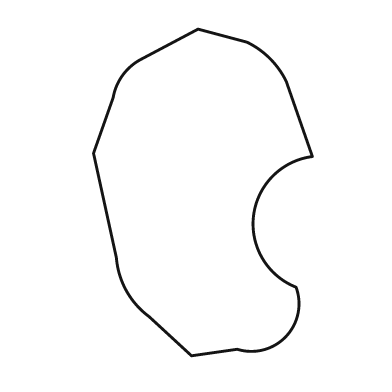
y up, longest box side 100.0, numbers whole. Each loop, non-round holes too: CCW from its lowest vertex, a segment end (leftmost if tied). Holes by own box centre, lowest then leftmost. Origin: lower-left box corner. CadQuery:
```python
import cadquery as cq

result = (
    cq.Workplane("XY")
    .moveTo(30.0, 0.0)
    .lineTo(44.0, 2.0)
    .threePointArc((59.0, 6.0), (62.0, 21.0))
    .threePointArc((49.0, 43.0), (67.0, 61.0))
    .lineTo(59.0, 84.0)
    .threePointArc((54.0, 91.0), (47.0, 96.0))
    .lineTo(32.0, 100.0)
    .lineTo(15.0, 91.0)
    .threePointArc((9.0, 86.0), (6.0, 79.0))
    .lineTo(0.0, 62.0)
    .lineTo(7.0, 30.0)
    .threePointArc((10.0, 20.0), (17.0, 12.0))
    .close()
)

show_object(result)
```